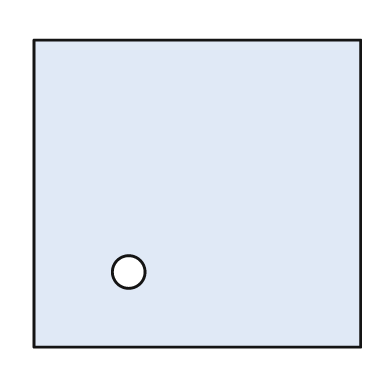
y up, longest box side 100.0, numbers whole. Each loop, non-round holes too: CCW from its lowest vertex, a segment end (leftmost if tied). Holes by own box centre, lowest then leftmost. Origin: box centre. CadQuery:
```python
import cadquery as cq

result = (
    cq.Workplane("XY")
    .moveTo(-50.0, -47.0)
    .lineTo(50.0, -47.0)
    .lineTo(50.0, 47.0)
    .lineTo(-50.0, 47.0)
    .close()
    .moveTo(-21.0, -24.0)
    .circle(5.0)
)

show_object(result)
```